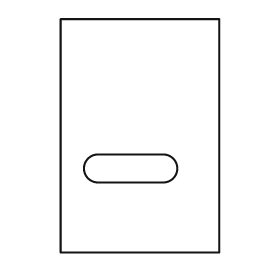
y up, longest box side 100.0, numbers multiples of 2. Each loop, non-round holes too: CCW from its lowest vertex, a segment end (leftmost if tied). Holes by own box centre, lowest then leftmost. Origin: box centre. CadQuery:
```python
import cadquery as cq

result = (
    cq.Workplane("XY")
    .moveTo(-34.0, -50.0)
    .lineTo(34.0, -50.0)
    .lineTo(34.0, 50.0)
    .lineTo(-34.0, 50.0)
    .close()
    .moveTo(-18.0, -20.0)
    .lineTo(10.0, -20.0)
    .threePointArc((16.0, -14.0), (10.0, -8.0))
    .lineTo(-18.0, -8.0)
    .threePointArc((-24.0, -14.0), (-18.0, -20.0))
    .close()
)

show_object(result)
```